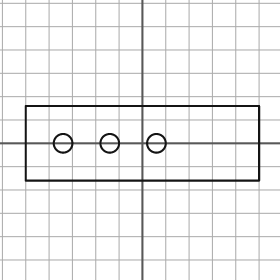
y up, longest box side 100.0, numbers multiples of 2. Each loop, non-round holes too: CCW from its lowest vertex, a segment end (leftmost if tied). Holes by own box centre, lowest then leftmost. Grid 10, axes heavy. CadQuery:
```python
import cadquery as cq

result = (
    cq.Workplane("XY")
    .moveTo(-50.0, -16.0)
    .lineTo(50.0, -16.0)
    .lineTo(50.0, 16.0)
    .lineTo(-50.0, 16.0)
    .close()
    .moveTo(-34.0, 0.0)
    .circle(4.0)
    .moveTo(-14.0, 0.0)
    .circle(4.0)
    .moveTo(6.0, 0.0)
    .circle(4.0)
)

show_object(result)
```